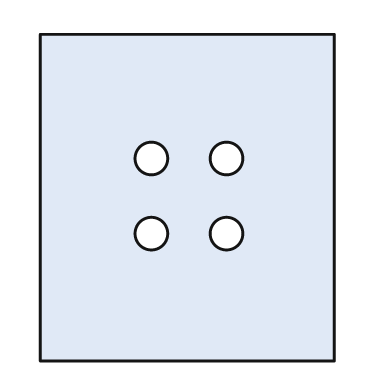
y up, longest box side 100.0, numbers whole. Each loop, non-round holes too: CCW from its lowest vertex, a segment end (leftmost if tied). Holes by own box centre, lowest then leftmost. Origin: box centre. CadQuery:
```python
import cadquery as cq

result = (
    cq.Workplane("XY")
    .moveTo(-45.0, -50.0)
    .lineTo(45.0, -50.0)
    .lineTo(45.0, 50.0)
    .lineTo(-45.0, 50.0)
    .close()
    .moveTo(-11.0, -11.0)
    .circle(5.0)
    .moveTo(12.0, -11.0)
    .circle(5.0)
    .moveTo(-11.0, 12.0)
    .circle(5.0)
    .moveTo(12.0, 12.0)
    .circle(5.0)
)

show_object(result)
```